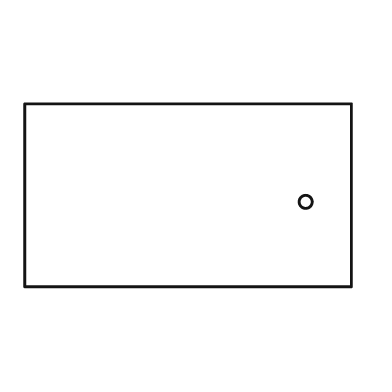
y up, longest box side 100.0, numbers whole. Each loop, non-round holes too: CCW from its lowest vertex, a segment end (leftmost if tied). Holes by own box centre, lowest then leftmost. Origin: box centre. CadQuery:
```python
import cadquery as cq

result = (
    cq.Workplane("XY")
    .moveTo(-50.0, -28.0)
    .lineTo(50.0, -28.0)
    .lineTo(50.0, 28.0)
    .lineTo(-50.0, 28.0)
    .close()
    .moveTo(36.0, -2.0)
    .circle(2.0)
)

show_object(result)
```